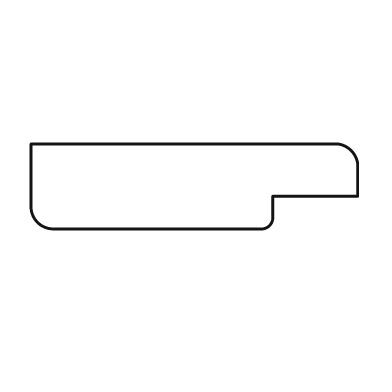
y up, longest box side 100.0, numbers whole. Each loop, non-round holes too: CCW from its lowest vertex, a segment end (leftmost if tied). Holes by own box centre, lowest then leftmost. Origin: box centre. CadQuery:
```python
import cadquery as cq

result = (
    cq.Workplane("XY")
    .moveTo(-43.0, -13.0)
    .lineTo(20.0, -13.0)
    .threePointArc((23.0, -12.0), (24.0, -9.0))
    .lineTo(24.0, -3.0)
    .lineTo(50.0, -3.0)
    .lineTo(50.0, 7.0)
    .threePointArc((48.0, 11.0), (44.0, 13.0))
    .lineTo(-50.0, 13.0)
    .lineTo(-50.0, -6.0)
    .threePointArc((-48.0, -11.0), (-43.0, -13.0))
    .close()
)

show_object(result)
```